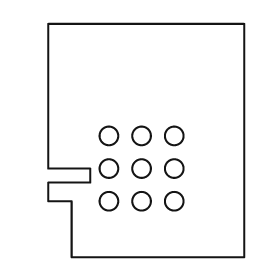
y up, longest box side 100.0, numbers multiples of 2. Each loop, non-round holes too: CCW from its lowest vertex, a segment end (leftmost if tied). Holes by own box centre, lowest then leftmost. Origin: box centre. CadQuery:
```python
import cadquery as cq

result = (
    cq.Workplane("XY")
    .moveTo(-32.0, -50.0)
    .lineTo(42.0, -50.0)
    .lineTo(42.0, 50.0)
    .lineTo(-42.0, 50.0)
    .lineTo(-42.0, -12.0)
    .lineTo(-24.0, -12.0)
    .lineTo(-24.0, -18.0)
    .lineTo(-42.0, -18.0)
    .lineTo(-42.0, -26.0)
    .lineTo(-32.0, -26.0)
    .close()
    .moveTo(-16.0, -26.0)
    .circle(4.0)
    .moveTo(-2.0, -26.0)
    .circle(4.0)
    .moveTo(12.0, -26.0)
    .circle(4.0)
    .moveTo(-16.0, -12.0)
    .circle(4.0)
    .moveTo(-2.0, -12.0)
    .circle(4.0)
    .moveTo(12.0, -12.0)
    .circle(4.0)
    .moveTo(-16.0, 2.0)
    .circle(4.0)
    .moveTo(-2.0, 2.0)
    .circle(4.0)
    .moveTo(12.0, 2.0)
    .circle(4.0)
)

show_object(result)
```